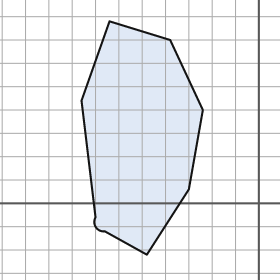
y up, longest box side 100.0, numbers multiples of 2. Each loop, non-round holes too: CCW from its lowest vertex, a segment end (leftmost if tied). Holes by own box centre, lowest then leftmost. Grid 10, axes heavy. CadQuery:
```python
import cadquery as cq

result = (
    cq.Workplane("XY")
    .moveTo(-48.0, -22.0)
    .lineTo(-30.0, 6.0)
    .lineTo(-24.0, 40.0)
    .lineTo(-38.0, 70.0)
    .lineTo(-64.0, 78.0)
    .lineTo(-76.0, 44.0)
    .lineTo(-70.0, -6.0)
    .threePointArc((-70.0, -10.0), (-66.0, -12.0))
    .close()
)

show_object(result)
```